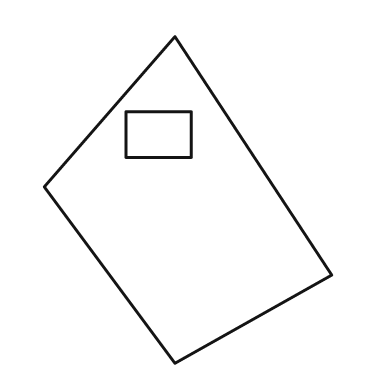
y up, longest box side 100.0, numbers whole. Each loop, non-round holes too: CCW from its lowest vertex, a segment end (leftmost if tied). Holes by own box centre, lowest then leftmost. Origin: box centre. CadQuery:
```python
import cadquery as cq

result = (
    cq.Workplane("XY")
    .moveTo(-4.0, -50.0)
    .lineTo(44.0, -23.0)
    .lineTo(-4.0, 50.0)
    .lineTo(-44.0, 4.0)
    .close()
    .moveTo(-19.0, 13.0)
    .lineTo(1.0, 13.0)
    .lineTo(1.0, 27.0)
    .lineTo(-19.0, 27.0)
    .close()
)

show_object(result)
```